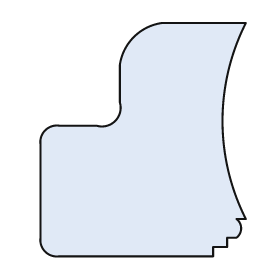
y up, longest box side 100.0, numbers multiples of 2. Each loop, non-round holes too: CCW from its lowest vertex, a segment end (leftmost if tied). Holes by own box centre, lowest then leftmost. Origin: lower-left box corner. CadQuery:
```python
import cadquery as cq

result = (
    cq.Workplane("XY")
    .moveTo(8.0, 0.0)
    .lineTo(74.0, 0.0)
    .lineTo(74.0, 4.0)
    .lineTo(80.0, 4.0)
    .lineTo(80.0, 8.0)
    .lineTo(84.0, 8.0)
    .threePointArc((86.0, 12.0), (84.0, 16.0))
    .lineTo(88.0, 16.0)
    .threePointArc((78.0, 58.0), (88.0, 100.0))
    .lineTo(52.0, 100.0)
    .threePointArc((40.0, 94.0), (34.0, 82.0))
    .lineTo(34.0, 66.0)
    .threePointArc((32.0, 58.0), (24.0, 56.0))
    .lineTo(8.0, 56.0)
    .threePointArc((2.0, 54.0), (0.0, 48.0))
    .lineTo(0.0, 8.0)
    .threePointArc((2.0, 2.0), (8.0, 0.0))
    .close()
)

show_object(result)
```